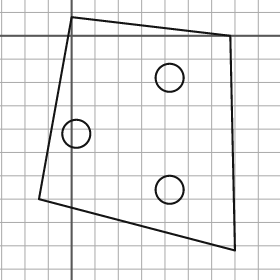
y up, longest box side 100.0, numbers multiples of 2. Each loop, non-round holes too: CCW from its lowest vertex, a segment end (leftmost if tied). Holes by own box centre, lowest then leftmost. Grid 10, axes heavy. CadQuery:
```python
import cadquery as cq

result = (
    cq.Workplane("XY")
    .moveTo(70.0, -92.0)
    .lineTo(68.0, 0.0)
    .lineTo(0.0, 8.0)
    .lineTo(-14.0, -70.0)
    .close()
    .moveTo(42.0, -66.0)
    .circle(6.0)
    .moveTo(2.0, -42.0)
    .circle(6.0)
    .moveTo(42.0, -18.0)
    .circle(6.0)
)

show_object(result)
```